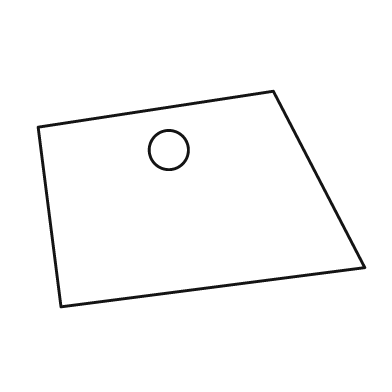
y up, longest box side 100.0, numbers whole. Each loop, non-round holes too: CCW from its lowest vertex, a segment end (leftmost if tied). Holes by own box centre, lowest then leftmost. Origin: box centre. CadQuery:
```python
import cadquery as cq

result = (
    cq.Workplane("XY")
    .moveTo(-43.0, -33.0)
    .lineTo(50.0, -21.0)
    .lineTo(22.0, 33.0)
    .lineTo(-50.0, 22.0)
    .close()
    .moveTo(-10.0, 15.0)
    .circle(6.0)
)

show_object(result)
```